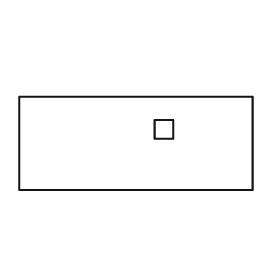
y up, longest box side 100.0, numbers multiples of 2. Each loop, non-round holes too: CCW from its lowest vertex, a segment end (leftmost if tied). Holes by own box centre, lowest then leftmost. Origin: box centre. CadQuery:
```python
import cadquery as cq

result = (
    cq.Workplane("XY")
    .moveTo(-50.0, -20.0)
    .lineTo(50.0, -20.0)
    .lineTo(50.0, 20.0)
    .lineTo(-50.0, 20.0)
    .close()
    .moveTo(8.0, 2.0)
    .lineTo(16.0, 2.0)
    .lineTo(16.0, 10.0)
    .lineTo(8.0, 10.0)
    .close()
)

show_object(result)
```